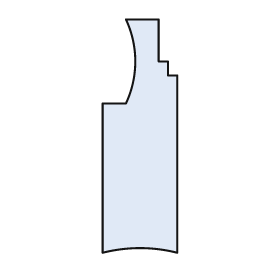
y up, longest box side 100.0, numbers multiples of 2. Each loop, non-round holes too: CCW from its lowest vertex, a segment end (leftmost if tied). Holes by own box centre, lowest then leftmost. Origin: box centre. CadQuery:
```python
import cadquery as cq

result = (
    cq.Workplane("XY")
    .moveTo(-16.0, -50.0)
    .threePointArc((0.0, -48.0), (16.0, -50.0))
    .lineTo(16.0, 26.0)
    .lineTo(12.0, 26.0)
    .lineTo(12.0, 32.0)
    .lineTo(8.0, 32.0)
    .lineTo(8.0, 50.0)
    .lineTo(-6.0, 50.0)
    .threePointArc((-2.0, 32.0), (-6.0, 14.0))
    .lineTo(-16.0, 14.0)
    .close()
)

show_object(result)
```